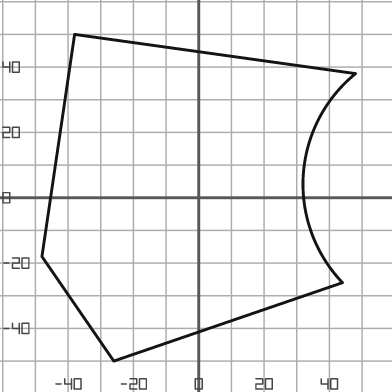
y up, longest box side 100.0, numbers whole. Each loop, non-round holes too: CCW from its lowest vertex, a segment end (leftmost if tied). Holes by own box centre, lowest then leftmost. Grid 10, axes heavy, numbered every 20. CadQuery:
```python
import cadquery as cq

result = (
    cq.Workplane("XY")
    .moveTo(-26.0, -50.0)
    .lineTo(44.0, -26.0)
    .threePointArc((32.0, 7.0), (48.0, 38.0))
    .lineTo(-38.0, 50.0)
    .lineTo(-48.0, -18.0)
    .close()
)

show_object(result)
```